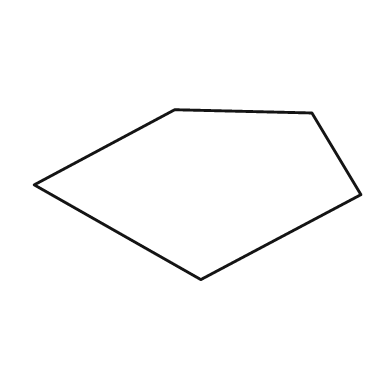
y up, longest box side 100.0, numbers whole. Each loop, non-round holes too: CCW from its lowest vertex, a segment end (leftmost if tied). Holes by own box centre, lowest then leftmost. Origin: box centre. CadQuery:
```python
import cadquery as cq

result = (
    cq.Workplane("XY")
    .moveTo(1.0, -26.0)
    .lineTo(50.0, 0.0)
    .lineTo(35.0, 25.0)
    .lineTo(-7.0, 26.0)
    .lineTo(-50.0, 3.0)
    .close()
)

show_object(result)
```